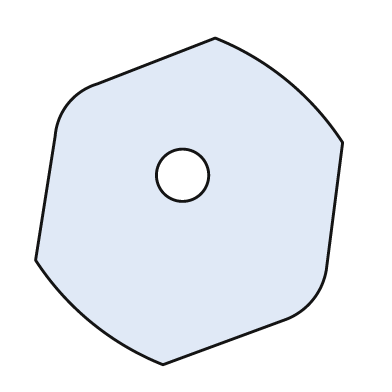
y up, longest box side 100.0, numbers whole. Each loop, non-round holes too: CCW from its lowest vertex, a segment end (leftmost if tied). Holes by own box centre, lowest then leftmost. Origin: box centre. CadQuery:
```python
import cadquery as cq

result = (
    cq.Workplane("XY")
    .moveTo(-8.0, -50.0)
    .lineTo(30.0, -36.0)
    .threePointArc((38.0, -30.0), (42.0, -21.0))
    .lineTo(47.0, 18.0)
    .threePointArc((30.0, 37.0), (8.0, 50.0))
    .lineTo(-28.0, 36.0)
    .threePointArc((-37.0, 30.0), (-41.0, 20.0))
    .lineTo(-47.0, -18.0)
    .threePointArc((-30.0, -37.0), (-8.0, -50.0))
    .close()
    .moveTo(-2.0, 8.0)
    .circle(8.0)
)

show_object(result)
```